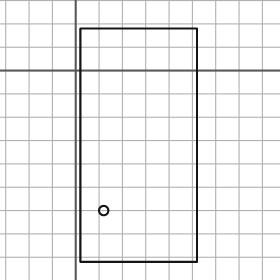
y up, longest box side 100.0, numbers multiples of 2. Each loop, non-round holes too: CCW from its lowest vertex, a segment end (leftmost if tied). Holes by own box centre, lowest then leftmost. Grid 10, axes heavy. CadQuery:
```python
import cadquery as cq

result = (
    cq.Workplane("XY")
    .moveTo(2.0, -82.0)
    .lineTo(52.0, -82.0)
    .lineTo(52.0, 18.0)
    .lineTo(2.0, 18.0)
    .close()
    .moveTo(12.0, -60.0)
    .circle(2.0)
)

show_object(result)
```